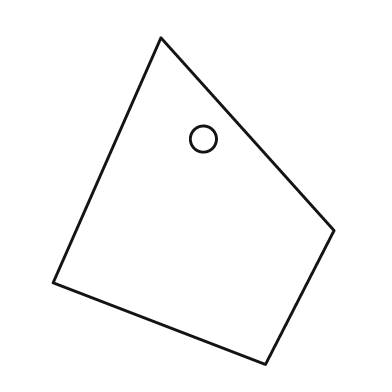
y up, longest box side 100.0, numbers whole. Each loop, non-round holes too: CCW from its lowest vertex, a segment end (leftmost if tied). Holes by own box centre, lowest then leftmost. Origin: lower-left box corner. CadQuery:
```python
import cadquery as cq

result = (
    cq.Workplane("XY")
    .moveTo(65.0, 0.0)
    .lineTo(86.0, 41.0)
    .lineTo(33.0, 100.0)
    .lineTo(0.0, 25.0)
    .close()
    .moveTo(46.0, 69.0)
    .circle(4.0)
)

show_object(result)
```